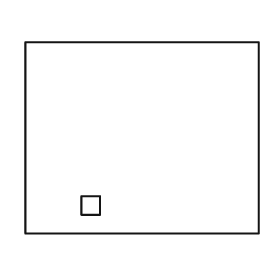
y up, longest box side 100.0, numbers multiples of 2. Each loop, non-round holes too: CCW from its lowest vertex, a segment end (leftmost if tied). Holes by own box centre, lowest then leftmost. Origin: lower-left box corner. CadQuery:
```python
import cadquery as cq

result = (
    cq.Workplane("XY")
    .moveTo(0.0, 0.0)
    .lineTo(100.0, 0.0)
    .lineTo(100.0, 82.0)
    .lineTo(0.0, 82.0)
    .close()
    .moveTo(24.0, 8.0)
    .lineTo(32.0, 8.0)
    .lineTo(32.0, 16.0)
    .lineTo(24.0, 16.0)
    .close()
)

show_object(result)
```